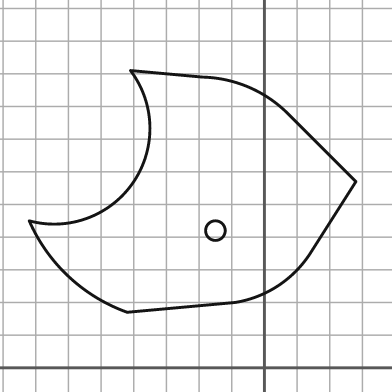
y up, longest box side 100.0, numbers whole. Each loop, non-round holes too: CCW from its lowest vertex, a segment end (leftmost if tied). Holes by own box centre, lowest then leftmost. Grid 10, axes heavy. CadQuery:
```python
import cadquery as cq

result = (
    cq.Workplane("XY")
    .moveTo(-42.0, 17.0)
    .lineTo(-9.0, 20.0)
    .threePointArc((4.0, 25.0), (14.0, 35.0))
    .lineTo(28.0, 57.0)
    .lineTo(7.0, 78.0)
    .threePointArc((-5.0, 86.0), (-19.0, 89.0))
    .lineTo(-41.0, 91.0)
    .threePointArc((-40.0, 57.0), (-72.0, 45.0))
    .threePointArc((-60.0, 28.0), (-42.0, 17.0))
    .close()
    .moveTo(-15.0, 42.0)
    .circle(3.0)
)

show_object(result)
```